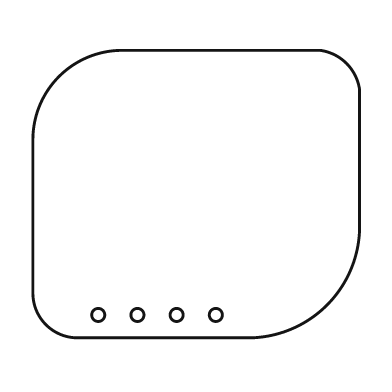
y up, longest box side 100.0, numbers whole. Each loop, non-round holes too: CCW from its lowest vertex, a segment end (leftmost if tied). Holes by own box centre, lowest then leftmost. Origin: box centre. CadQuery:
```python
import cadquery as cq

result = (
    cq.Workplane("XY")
    .moveTo(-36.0, -44.0)
    .lineTo(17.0, -44.0)
    .threePointArc((40.0, -34.0), (50.0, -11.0))
    .lineTo(50.0, 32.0)
    .threePointArc((46.0, 40.0), (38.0, 44.0))
    .lineTo(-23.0, 44.0)
    .threePointArc((-42.0, 36.0), (-50.0, 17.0))
    .lineTo(-50.0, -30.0)
    .threePointArc((-46.0, -40.0), (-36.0, -44.0))
    .close()
    .moveTo(-30.0, -37.0)
    .circle(2.0)
    .moveTo(-18.0, -37.0)
    .circle(2.0)
    .moveTo(-6.0, -37.0)
    .circle(2.0)
    .moveTo(6.0, -37.0)
    .circle(2.0)
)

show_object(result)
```